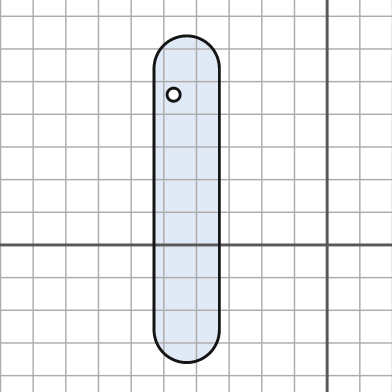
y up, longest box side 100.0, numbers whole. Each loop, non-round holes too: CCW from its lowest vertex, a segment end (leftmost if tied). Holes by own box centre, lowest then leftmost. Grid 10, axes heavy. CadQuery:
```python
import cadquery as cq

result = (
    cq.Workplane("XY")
    .moveTo(-53.0, -26.0)
    .threePointArc((-43.0, -36.0), (-33.0, -26.0))
    .lineTo(-33.0, 54.0)
    .threePointArc((-43.0, 64.0), (-53.0, 54.0))
    .close()
    .moveTo(-47.0, 46.0)
    .circle(2.0)
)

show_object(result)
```